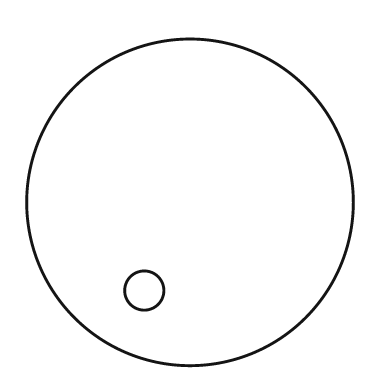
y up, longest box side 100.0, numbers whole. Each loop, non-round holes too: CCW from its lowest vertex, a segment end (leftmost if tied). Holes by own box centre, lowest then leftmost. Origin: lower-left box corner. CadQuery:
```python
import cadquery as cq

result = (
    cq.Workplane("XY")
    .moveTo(50.0, 50.0)
    .circle(50.0)
    .moveTo(36.0, 23.0)
    .circle(6.0)
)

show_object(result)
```